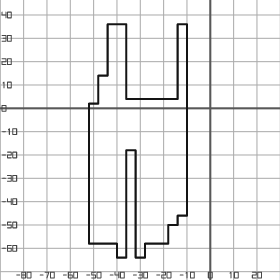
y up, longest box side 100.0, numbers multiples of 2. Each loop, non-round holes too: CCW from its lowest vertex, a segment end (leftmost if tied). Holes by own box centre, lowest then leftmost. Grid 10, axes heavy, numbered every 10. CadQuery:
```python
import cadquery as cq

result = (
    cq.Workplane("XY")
    .moveTo(-40.0, -64.0)
    .lineTo(-36.0, -64.0)
    .lineTo(-36.0, -18.0)
    .lineTo(-32.0, -18.0)
    .lineTo(-32.0, -64.0)
    .lineTo(-28.0, -64.0)
    .lineTo(-28.0, -58.0)
    .lineTo(-18.0, -58.0)
    .lineTo(-18.0, -50.0)
    .lineTo(-14.0, -50.0)
    .lineTo(-14.0, -46.0)
    .lineTo(-10.0, -46.0)
    .lineTo(-10.0, 36.0)
    .lineTo(-14.0, 36.0)
    .lineTo(-14.0, 4.0)
    .lineTo(-36.0, 4.0)
    .lineTo(-36.0, 36.0)
    .lineTo(-44.0, 36.0)
    .lineTo(-44.0, 14.0)
    .lineTo(-48.0, 14.0)
    .lineTo(-48.0, 2.0)
    .lineTo(-52.0, 2.0)
    .lineTo(-52.0, -58.0)
    .lineTo(-40.0, -58.0)
    .close()
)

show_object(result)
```